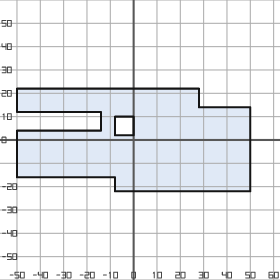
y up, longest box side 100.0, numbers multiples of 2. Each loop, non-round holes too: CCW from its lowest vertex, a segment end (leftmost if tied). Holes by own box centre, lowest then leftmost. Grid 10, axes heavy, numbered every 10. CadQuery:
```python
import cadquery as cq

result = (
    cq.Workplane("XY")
    .moveTo(-8.0, -22.0)
    .lineTo(50.0, -22.0)
    .lineTo(50.0, 14.0)
    .lineTo(28.0, 14.0)
    .lineTo(28.0, 22.0)
    .lineTo(-50.0, 22.0)
    .lineTo(-50.0, 12.0)
    .lineTo(-14.0, 12.0)
    .lineTo(-14.0, 4.0)
    .lineTo(-50.0, 4.0)
    .lineTo(-50.0, -16.0)
    .lineTo(-8.0, -16.0)
    .close()
    .moveTo(-8.0, 2.0)
    .lineTo(0.0, 2.0)
    .lineTo(0.0, 10.0)
    .lineTo(-8.0, 10.0)
    .close()
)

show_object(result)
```